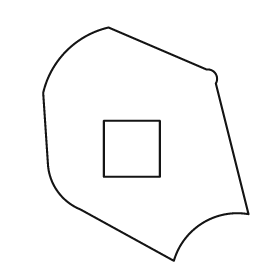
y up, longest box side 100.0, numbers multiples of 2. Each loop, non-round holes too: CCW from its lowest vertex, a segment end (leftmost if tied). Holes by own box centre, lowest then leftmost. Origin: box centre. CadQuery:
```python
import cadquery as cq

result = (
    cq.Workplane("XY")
    .moveTo(12.0, -50.0)
    .threePointArc((24.0, -34.0), (44.0, -30.0))
    .lineTo(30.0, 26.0)
    .threePointArc((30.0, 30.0), (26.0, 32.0))
    .lineTo(-16.0, 50.0)
    .threePointArc((-34.0, 40.0), (-44.0, 22.0))
    .lineTo(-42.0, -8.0)
    .threePointArc((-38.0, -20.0), (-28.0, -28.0))
    .close()
    .moveTo(-18.0, -14.0)
    .lineTo(6.0, -14.0)
    .lineTo(6.0, 10.0)
    .lineTo(-18.0, 10.0)
    .close()
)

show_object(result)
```